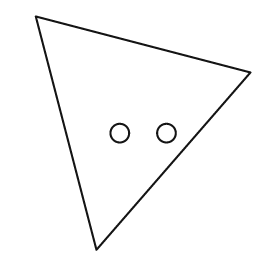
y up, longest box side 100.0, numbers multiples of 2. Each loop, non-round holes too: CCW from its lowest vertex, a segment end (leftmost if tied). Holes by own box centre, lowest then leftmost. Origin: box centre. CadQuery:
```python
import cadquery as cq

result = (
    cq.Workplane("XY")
    .moveTo(-20.0, -50.0)
    .lineTo(46.0, 26.0)
    .lineTo(-46.0, 50.0)
    .close()
    .moveTo(-10.0, 0.0)
    .circle(4.0)
    .moveTo(10.0, 0.0)
    .circle(4.0)
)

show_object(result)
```